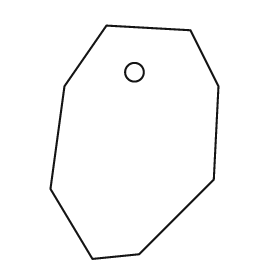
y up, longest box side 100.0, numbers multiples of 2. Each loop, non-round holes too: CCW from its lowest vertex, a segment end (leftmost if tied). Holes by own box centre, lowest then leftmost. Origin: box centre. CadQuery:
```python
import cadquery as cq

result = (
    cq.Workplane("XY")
    .moveTo(-18.0, -50.0)
    .lineTo(2.0, -48.0)
    .lineTo(34.0, -16.0)
    .lineTo(36.0, 24.0)
    .lineTo(24.0, 48.0)
    .lineTo(-12.0, 50.0)
    .lineTo(-30.0, 24.0)
    .lineTo(-36.0, -20.0)
    .close()
    .moveTo(0.0, 30.0)
    .circle(4.0)
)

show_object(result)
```